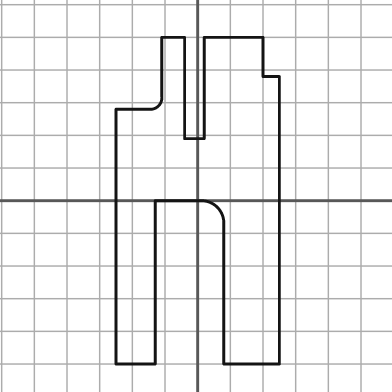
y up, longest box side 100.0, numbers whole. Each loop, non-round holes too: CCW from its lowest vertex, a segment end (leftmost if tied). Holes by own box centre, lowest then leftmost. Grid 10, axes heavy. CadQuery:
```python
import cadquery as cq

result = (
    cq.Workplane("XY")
    .moveTo(-25.0, -50.0)
    .lineTo(-13.0, -50.0)
    .lineTo(-13.0, 0.0)
    .lineTo(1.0, 0.0)
    .threePointArc((6.0, -2.0), (8.0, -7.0))
    .lineTo(8.0, -50.0)
    .lineTo(25.0, -50.0)
    .lineTo(25.0, 38.0)
    .lineTo(20.0, 38.0)
    .lineTo(20.0, 50.0)
    .lineTo(2.0, 50.0)
    .lineTo(2.0, 19.0)
    .lineTo(-4.0, 19.0)
    .lineTo(-4.0, 50.0)
    .lineTo(-11.0, 50.0)
    .lineTo(-11.0, 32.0)
    .threePointArc((-12.0, 29.0), (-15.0, 28.0))
    .lineTo(-25.0, 28.0)
    .close()
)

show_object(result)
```